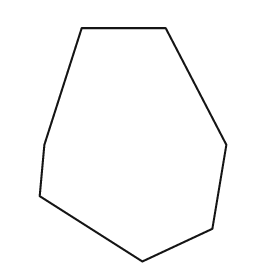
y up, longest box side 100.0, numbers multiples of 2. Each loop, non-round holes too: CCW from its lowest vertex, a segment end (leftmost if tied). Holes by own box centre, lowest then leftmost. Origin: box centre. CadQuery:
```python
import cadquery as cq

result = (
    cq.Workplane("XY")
    .moveTo(4.0, -50.0)
    .lineTo(34.0, -36.0)
    .lineTo(40.0, 0.0)
    .lineTo(14.0, 50.0)
    .lineTo(-22.0, 50.0)
    .lineTo(-38.0, 0.0)
    .lineTo(-40.0, -22.0)
    .close()
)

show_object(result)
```